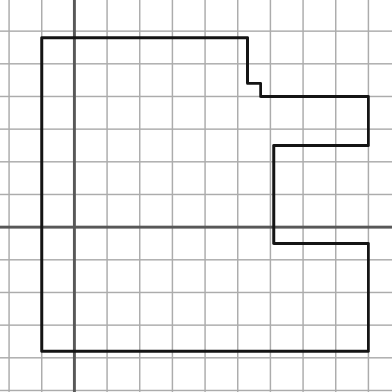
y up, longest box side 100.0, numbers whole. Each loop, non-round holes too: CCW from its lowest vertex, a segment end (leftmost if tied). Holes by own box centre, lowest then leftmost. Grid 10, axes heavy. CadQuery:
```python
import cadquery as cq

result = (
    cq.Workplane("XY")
    .moveTo(-10.0, -38.0)
    .lineTo(90.0, -38.0)
    .lineTo(90.0, -5.0)
    .lineTo(61.0, -5.0)
    .lineTo(61.0, 25.0)
    .lineTo(90.0, 25.0)
    .lineTo(90.0, 40.0)
    .lineTo(57.0, 40.0)
    .lineTo(57.0, 44.0)
    .lineTo(53.0, 44.0)
    .lineTo(53.0, 58.0)
    .lineTo(-10.0, 58.0)
    .close()
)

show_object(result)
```